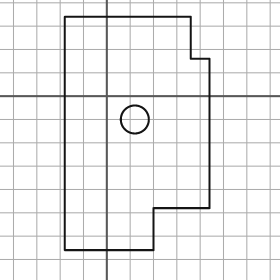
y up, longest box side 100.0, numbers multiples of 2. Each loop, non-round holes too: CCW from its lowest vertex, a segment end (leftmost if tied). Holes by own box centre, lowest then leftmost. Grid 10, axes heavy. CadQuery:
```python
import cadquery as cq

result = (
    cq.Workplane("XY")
    .moveTo(-18.0, -66.0)
    .lineTo(20.0, -66.0)
    .lineTo(20.0, -48.0)
    .lineTo(44.0, -48.0)
    .lineTo(44.0, 16.0)
    .lineTo(36.0, 16.0)
    .lineTo(36.0, 34.0)
    .lineTo(-18.0, 34.0)
    .close()
    .moveTo(12.0, -10.0)
    .circle(6.0)
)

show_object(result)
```